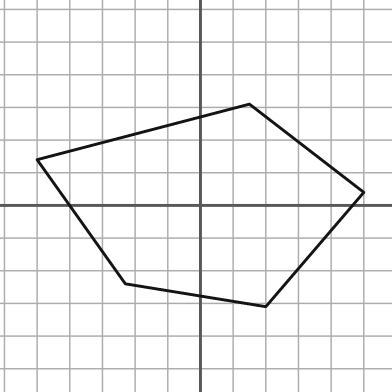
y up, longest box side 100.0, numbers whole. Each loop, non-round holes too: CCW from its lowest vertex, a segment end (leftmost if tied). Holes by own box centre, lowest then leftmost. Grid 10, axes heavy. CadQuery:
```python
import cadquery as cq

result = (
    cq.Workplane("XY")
    .moveTo(20.0, -31.0)
    .lineTo(50.0, 4.0)
    .lineTo(15.0, 31.0)
    .lineTo(-50.0, 14.0)
    .lineTo(-23.0, -24.0)
    .close()
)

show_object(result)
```